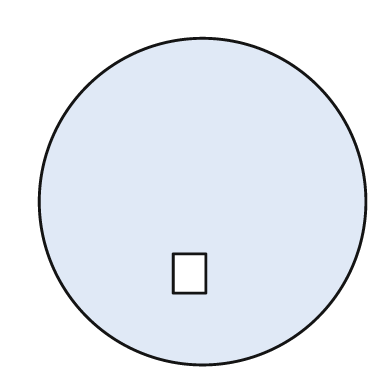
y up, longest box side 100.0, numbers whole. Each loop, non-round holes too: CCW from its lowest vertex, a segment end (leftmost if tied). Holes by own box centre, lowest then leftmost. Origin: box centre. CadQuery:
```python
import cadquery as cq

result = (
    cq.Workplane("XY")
    .moveTo(0.0, 0.0)
    .circle(50.0)
    .moveTo(-9.0, -28.0)
    .lineTo(1.0, -28.0)
    .lineTo(1.0, -16.0)
    .lineTo(-9.0, -16.0)
    .close()
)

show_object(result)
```